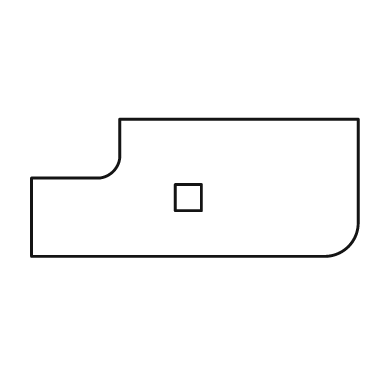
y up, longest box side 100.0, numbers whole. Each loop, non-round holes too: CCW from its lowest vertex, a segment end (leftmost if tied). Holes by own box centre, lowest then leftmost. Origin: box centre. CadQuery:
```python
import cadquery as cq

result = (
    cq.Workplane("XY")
    .moveTo(-50.0, -21.0)
    .lineTo(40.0, -21.0)
    .threePointArc((47.0, -18.0), (50.0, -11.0))
    .lineTo(50.0, 21.0)
    .lineTo(-23.0, 21.0)
    .lineTo(-23.0, 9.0)
    .threePointArc((-25.0, 5.0), (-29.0, 3.0))
    .lineTo(-50.0, 3.0)
    .close()
    .moveTo(-6.0, -7.0)
    .lineTo(2.0, -7.0)
    .lineTo(2.0, 1.0)
    .lineTo(-6.0, 1.0)
    .close()
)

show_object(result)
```